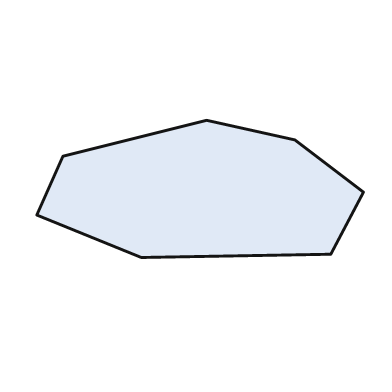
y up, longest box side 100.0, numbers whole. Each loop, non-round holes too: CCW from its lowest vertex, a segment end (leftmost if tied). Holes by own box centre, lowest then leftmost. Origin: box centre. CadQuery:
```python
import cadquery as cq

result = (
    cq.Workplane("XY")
    .moveTo(-18.0, -21.0)
    .lineTo(40.0, -20.0)
    .lineTo(50.0, -1.0)
    .lineTo(29.0, 15.0)
    .lineTo(2.0, 21.0)
    .lineTo(-42.0, 10.0)
    .lineTo(-50.0, -8.0)
    .close()
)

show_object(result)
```